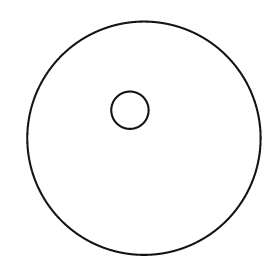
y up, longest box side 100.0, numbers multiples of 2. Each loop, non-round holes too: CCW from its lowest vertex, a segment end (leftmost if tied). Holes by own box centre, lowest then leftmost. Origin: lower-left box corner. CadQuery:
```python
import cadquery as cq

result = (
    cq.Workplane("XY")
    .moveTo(50.0, 50.0)
    .circle(50.0)
    .moveTo(44.0, 62.0)
    .circle(8.0)
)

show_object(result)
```